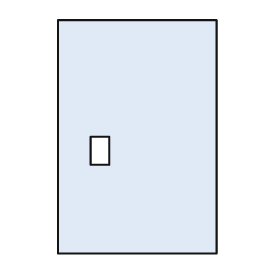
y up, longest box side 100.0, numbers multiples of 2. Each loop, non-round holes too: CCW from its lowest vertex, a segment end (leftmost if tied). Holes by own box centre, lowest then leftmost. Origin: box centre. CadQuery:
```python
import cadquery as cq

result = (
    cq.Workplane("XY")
    .moveTo(-34.0, -50.0)
    .lineTo(34.0, -50.0)
    .lineTo(34.0, 50.0)
    .lineTo(-34.0, 50.0)
    .close()
    .moveTo(-20.0, -12.0)
    .lineTo(-12.0, -12.0)
    .lineTo(-12.0, 0.0)
    .lineTo(-20.0, 0.0)
    .close()
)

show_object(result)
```